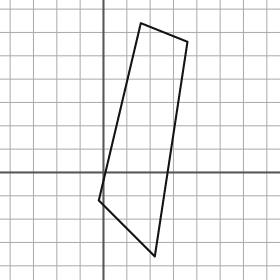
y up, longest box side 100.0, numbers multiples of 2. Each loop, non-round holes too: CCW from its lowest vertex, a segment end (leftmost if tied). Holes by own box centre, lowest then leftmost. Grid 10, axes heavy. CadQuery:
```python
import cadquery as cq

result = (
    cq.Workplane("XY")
    .moveTo(22.0, -36.0)
    .lineTo(36.0, 56.0)
    .lineTo(16.0, 64.0)
    .lineTo(-2.0, -12.0)
    .close()
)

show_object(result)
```